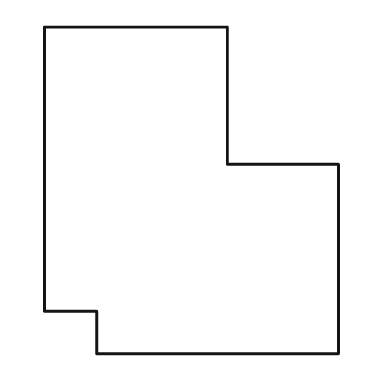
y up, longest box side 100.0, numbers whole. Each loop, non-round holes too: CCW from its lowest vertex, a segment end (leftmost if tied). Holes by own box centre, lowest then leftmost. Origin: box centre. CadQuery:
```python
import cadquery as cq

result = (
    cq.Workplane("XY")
    .moveTo(-29.0, -50.0)
    .lineTo(45.0, -50.0)
    .lineTo(45.0, 8.0)
    .lineTo(11.0, 8.0)
    .lineTo(11.0, 50.0)
    .lineTo(-45.0, 50.0)
    .lineTo(-45.0, -37.0)
    .lineTo(-29.0, -37.0)
    .close()
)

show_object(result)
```